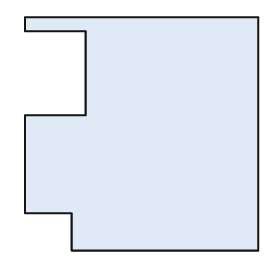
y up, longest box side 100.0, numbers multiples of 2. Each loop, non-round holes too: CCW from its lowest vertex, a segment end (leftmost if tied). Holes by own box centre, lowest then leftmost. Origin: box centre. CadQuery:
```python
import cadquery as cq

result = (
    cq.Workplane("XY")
    .moveTo(-30.0, -50.0)
    .lineTo(50.0, -50.0)
    .lineTo(50.0, 50.0)
    .lineTo(-50.0, 50.0)
    .lineTo(-50.0, 44.0)
    .lineTo(-24.0, 44.0)
    .lineTo(-24.0, 8.0)
    .lineTo(-50.0, 8.0)
    .lineTo(-50.0, -34.0)
    .lineTo(-30.0, -34.0)
    .close()
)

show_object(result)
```